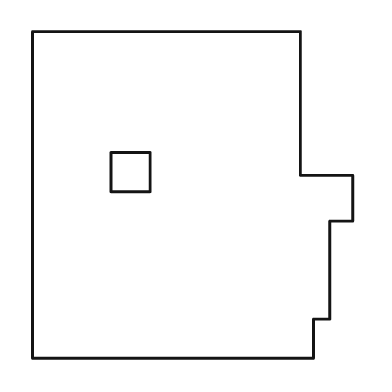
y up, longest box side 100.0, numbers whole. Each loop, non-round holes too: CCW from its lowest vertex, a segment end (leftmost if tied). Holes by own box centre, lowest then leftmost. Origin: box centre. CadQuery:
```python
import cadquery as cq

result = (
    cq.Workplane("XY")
    .moveTo(-49.0, -50.0)
    .lineTo(37.0, -50.0)
    .lineTo(37.0, -38.0)
    .lineTo(42.0, -38.0)
    .lineTo(42.0, -8.0)
    .lineTo(49.0, -8.0)
    .lineTo(49.0, 6.0)
    .lineTo(33.0, 6.0)
    .lineTo(33.0, 50.0)
    .lineTo(-49.0, 50.0)
    .close()
    .moveTo(-25.0, 1.0)
    .lineTo(-13.0, 1.0)
    .lineTo(-13.0, 13.0)
    .lineTo(-25.0, 13.0)
    .close()
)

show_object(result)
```